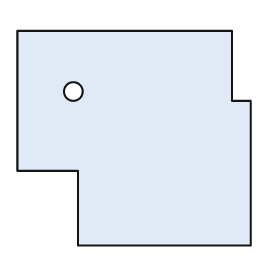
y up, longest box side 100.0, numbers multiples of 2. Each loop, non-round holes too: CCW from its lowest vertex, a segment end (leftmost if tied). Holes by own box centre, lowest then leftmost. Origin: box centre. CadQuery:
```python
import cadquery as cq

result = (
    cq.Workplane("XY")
    .moveTo(-24.0, -46.0)
    .lineTo(50.0, -46.0)
    .lineTo(50.0, 16.0)
    .lineTo(42.0, 16.0)
    .lineTo(42.0, 46.0)
    .lineTo(-50.0, 46.0)
    .lineTo(-50.0, -14.0)
    .lineTo(-24.0, -14.0)
    .close()
    .moveTo(-26.0, 20.0)
    .circle(4.0)
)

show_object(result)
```